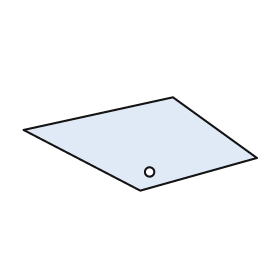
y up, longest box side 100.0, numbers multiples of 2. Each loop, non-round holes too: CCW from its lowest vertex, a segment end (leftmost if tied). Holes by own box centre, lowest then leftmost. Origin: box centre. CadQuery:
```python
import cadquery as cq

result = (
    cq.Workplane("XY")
    .moveTo(0.0, -20.0)
    .lineTo(50.0, -6.0)
    .lineTo(14.0, 20.0)
    .lineTo(-50.0, 6.0)
    .close()
    .moveTo(4.0, -12.0)
    .circle(2.0)
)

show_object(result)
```